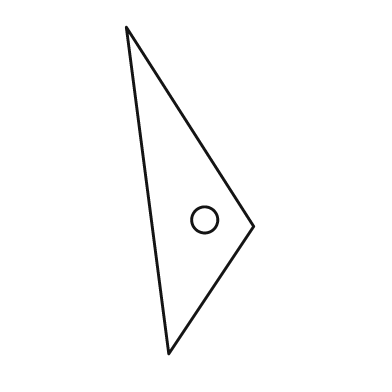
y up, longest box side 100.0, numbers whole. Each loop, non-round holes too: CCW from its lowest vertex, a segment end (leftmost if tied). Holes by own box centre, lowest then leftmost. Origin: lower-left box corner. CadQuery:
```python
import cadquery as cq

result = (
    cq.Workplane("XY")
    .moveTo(13.0, 0.0)
    .lineTo(39.0, 39.0)
    .lineTo(0.0, 100.0)
    .close()
    .moveTo(24.0, 41.0)
    .circle(4.0)
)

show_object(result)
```